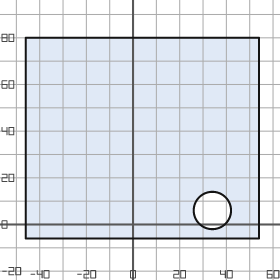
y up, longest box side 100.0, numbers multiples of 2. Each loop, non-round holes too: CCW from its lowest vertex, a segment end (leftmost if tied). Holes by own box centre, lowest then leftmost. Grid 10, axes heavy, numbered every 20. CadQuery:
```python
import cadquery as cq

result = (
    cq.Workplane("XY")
    .moveTo(-46.0, -6.0)
    .lineTo(54.0, -6.0)
    .lineTo(54.0, 80.0)
    .lineTo(-46.0, 80.0)
    .close()
    .moveTo(34.0, 6.0)
    .circle(8.0)
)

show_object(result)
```